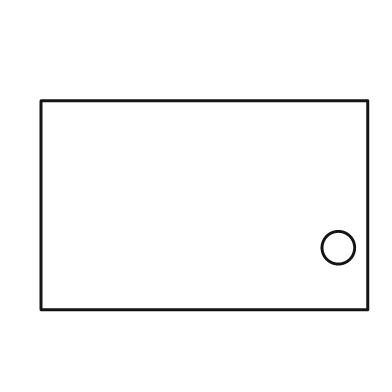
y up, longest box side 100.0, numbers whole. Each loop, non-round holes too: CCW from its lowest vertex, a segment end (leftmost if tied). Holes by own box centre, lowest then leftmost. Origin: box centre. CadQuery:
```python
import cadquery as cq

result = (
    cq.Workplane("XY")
    .moveTo(-50.0, -32.0)
    .lineTo(50.0, -32.0)
    .lineTo(50.0, 32.0)
    .lineTo(-50.0, 32.0)
    .close()
    .moveTo(41.0, -13.0)
    .circle(5.0)
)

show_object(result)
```